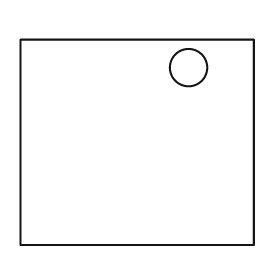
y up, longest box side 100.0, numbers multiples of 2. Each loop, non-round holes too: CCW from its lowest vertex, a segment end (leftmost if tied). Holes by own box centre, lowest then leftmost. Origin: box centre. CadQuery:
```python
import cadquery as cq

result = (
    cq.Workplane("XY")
    .moveTo(-50.0, -44.0)
    .lineTo(50.0, -44.0)
    .lineTo(50.0, 44.0)
    .lineTo(-50.0, 44.0)
    .close()
    .moveTo(22.0, 32.0)
    .circle(8.0)
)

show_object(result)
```